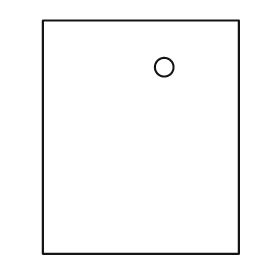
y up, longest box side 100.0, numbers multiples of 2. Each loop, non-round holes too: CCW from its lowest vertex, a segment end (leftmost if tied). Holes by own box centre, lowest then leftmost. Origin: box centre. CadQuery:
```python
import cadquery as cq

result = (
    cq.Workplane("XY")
    .moveTo(-42.0, -50.0)
    .lineTo(42.0, -50.0)
    .lineTo(42.0, 50.0)
    .lineTo(-42.0, 50.0)
    .close()
    .moveTo(10.0, 30.0)
    .circle(4.0)
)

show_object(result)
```